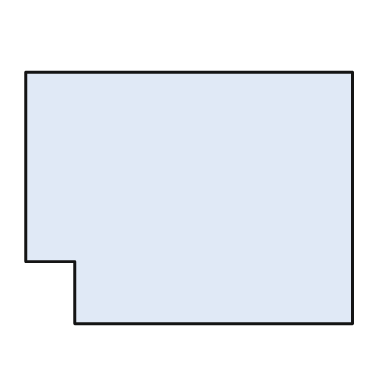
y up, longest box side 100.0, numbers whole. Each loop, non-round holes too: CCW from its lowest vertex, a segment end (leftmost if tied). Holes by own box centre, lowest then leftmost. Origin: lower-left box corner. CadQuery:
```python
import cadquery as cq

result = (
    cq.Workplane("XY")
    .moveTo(15.0, 0.0)
    .lineTo(100.0, 0.0)
    .lineTo(100.0, 77.0)
    .lineTo(0.0, 77.0)
    .lineTo(0.0, 19.0)
    .lineTo(15.0, 19.0)
    .close()
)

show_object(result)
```